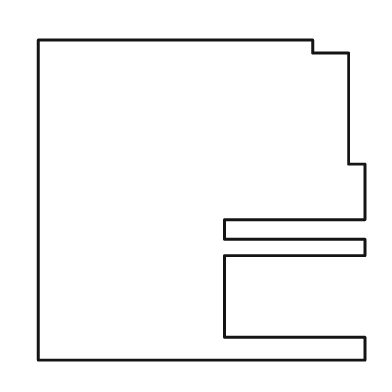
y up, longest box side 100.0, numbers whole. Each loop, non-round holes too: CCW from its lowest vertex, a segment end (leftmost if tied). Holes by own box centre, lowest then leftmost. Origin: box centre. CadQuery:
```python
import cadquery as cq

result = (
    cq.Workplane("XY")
    .moveTo(-50.0, -49.0)
    .lineTo(50.0, -49.0)
    .lineTo(50.0, -42.0)
    .lineTo(7.0, -42.0)
    .lineTo(7.0, -17.0)
    .lineTo(50.0, -17.0)
    .lineTo(50.0, -12.0)
    .lineTo(7.0, -12.0)
    .lineTo(7.0, -6.0)
    .lineTo(50.0, -6.0)
    .lineTo(50.0, 11.0)
    .lineTo(45.0, 11.0)
    .lineTo(45.0, 45.0)
    .lineTo(34.0, 45.0)
    .lineTo(34.0, 49.0)
    .lineTo(-50.0, 49.0)
    .close()
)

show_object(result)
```